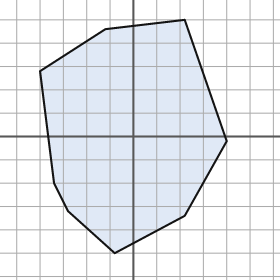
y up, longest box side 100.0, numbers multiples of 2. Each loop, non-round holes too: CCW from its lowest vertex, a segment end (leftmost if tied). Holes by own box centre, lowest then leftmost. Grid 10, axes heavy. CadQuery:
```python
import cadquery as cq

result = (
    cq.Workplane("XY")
    .moveTo(-8.0, -50.0)
    .lineTo(22.0, -34.0)
    .lineTo(40.0, -2.0)
    .lineTo(22.0, 50.0)
    .lineTo(-12.0, 46.0)
    .lineTo(-40.0, 28.0)
    .lineTo(-34.0, -20.0)
    .lineTo(-28.0, -32.0)
    .close()
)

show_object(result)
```